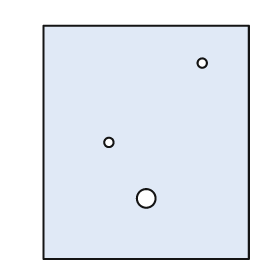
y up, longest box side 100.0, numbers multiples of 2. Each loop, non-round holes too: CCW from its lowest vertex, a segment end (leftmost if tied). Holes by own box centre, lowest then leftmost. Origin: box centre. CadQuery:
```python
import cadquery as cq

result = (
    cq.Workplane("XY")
    .moveTo(-44.0, -50.0)
    .lineTo(44.0, -50.0)
    .lineTo(44.0, 50.0)
    .lineTo(-44.0, 50.0)
    .close()
    .moveTo(0.0, -24.0)
    .circle(4.0)
    .moveTo(-16.0, 0.0)
    .circle(2.0)
    .moveTo(24.0, 34.0)
    .circle(2.0)
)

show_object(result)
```